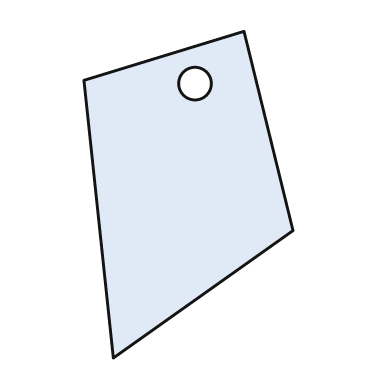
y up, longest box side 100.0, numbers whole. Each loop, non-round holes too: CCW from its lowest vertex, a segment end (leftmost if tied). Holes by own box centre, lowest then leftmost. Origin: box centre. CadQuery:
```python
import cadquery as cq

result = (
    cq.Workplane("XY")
    .moveTo(-23.0, -50.0)
    .lineTo(32.0, -11.0)
    .lineTo(17.0, 50.0)
    .lineTo(-32.0, 35.0)
    .close()
    .moveTo(2.0, 34.0)
    .circle(5.0)
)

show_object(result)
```